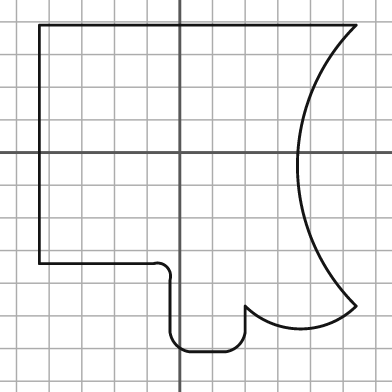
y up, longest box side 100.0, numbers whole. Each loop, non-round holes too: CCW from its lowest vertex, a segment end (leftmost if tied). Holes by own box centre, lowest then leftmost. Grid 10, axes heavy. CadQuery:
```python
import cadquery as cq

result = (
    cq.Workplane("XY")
    .moveTo(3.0, -61.0)
    .lineTo(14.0, -61.0)
    .threePointArc((18.0, -59.0), (20.0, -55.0))
    .lineTo(20.0, -47.0)
    .threePointArc((37.0, -54.0), (54.0, -47.0))
    .threePointArc((36.0, -4.0), (54.0, 39.0))
    .lineTo(-43.0, 39.0)
    .lineTo(-43.0, -34.0)
    .lineTo(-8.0, -34.0)
    .threePointArc((-4.0, -35.0), (-3.0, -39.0))
    .lineTo(-3.0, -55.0)
    .threePointArc((-1.0, -59.0), (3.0, -61.0))
    .close()
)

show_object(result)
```